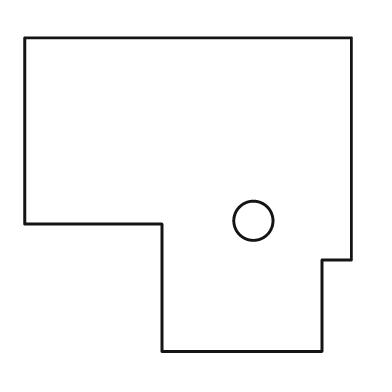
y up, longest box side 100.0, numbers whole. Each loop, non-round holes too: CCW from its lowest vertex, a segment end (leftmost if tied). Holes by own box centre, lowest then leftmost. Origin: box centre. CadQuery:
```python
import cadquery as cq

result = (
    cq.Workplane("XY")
    .moveTo(-8.0, -48.0)
    .lineTo(41.0, -48.0)
    .lineTo(41.0, -20.0)
    .lineTo(50.0, -20.0)
    .lineTo(50.0, 48.0)
    .lineTo(-50.0, 48.0)
    .lineTo(-50.0, -9.0)
    .lineTo(-8.0, -9.0)
    .close()
    .moveTo(20.0, -8.0)
    .circle(6.0)
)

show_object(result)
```